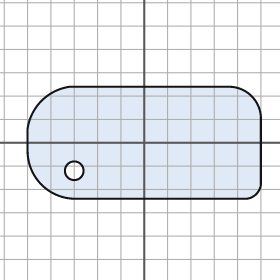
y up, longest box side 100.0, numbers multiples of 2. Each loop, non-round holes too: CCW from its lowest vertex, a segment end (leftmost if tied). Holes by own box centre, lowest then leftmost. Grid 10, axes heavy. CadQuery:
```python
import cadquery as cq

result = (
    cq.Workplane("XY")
    .moveTo(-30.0, -24.0)
    .lineTo(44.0, -24.0)
    .threePointArc((48.0, -22.0), (50.0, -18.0))
    .lineTo(50.0, 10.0)
    .threePointArc((46.0, 20.0), (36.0, 24.0))
    .lineTo(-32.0, 24.0)
    .threePointArc((-44.0, 18.0), (-50.0, 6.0))
    .lineTo(-50.0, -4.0)
    .threePointArc((-44.0, -18.0), (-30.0, -24.0))
    .close()
    .moveTo(-30.0, -12.0)
    .circle(4.0)
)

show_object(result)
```